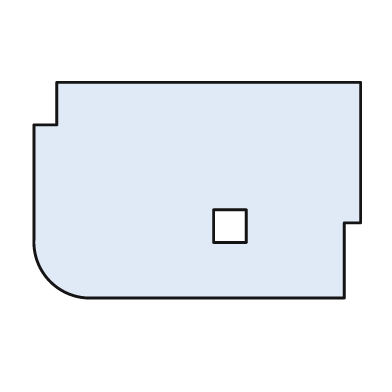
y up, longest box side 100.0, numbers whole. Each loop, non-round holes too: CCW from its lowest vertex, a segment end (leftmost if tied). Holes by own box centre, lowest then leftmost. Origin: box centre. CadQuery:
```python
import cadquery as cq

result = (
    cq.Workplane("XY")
    .moveTo(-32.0, -33.0)
    .lineTo(45.0, -33.0)
    .lineTo(45.0, -10.0)
    .lineTo(50.0, -10.0)
    .lineTo(50.0, 33.0)
    .lineTo(-43.0, 33.0)
    .lineTo(-43.0, 20.0)
    .lineTo(-50.0, 20.0)
    .lineTo(-50.0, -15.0)
    .threePointArc((-45.0, -28.0), (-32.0, -33.0))
    .close()
    .moveTo(5.0, -16.0)
    .lineTo(15.0, -16.0)
    .lineTo(15.0, -6.0)
    .lineTo(5.0, -6.0)
    .close()
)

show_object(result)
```